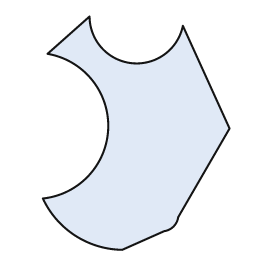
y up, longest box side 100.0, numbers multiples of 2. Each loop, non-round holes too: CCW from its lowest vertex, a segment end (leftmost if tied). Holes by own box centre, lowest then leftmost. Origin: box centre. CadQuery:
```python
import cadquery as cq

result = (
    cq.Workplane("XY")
    .moveTo(-6.0, -50.0)
    .lineTo(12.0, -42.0)
    .threePointArc((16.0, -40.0), (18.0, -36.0))
    .lineTo(40.0, 2.0)
    .lineTo(20.0, 46.0)
    .threePointArc((-2.0, 30.0), (-20.0, 50.0))
    .lineTo(-38.0, 34.0)
    .threePointArc((-12.0, 2.0), (-40.0, -28.0))
    .threePointArc((-26.0, -44.0), (-6.0, -50.0))
    .close()
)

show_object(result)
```